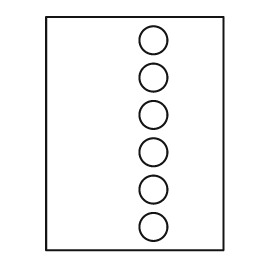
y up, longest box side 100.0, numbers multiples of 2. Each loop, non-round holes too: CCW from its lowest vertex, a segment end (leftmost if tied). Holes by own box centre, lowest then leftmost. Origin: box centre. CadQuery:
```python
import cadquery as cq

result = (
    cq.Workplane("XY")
    .moveTo(-38.0, -50.0)
    .lineTo(38.0, -50.0)
    .lineTo(38.0, 50.0)
    .lineTo(-38.0, 50.0)
    .close()
    .moveTo(8.0, -40.0)
    .circle(6.0)
    .moveTo(8.0, -24.0)
    .circle(6.0)
    .moveTo(8.0, -8.0)
    .circle(6.0)
    .moveTo(8.0, 8.0)
    .circle(6.0)
    .moveTo(8.0, 24.0)
    .circle(6.0)
    .moveTo(8.0, 40.0)
    .circle(6.0)
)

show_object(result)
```